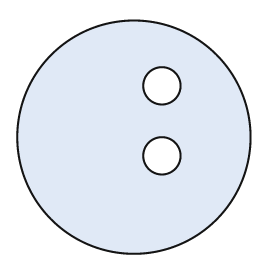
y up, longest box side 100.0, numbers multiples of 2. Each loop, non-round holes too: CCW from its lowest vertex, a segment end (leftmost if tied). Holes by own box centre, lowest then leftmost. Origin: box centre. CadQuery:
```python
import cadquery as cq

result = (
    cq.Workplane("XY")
    .moveTo(0.0, 0.0)
    .circle(50.0)
    .moveTo(12.0, -8.0)
    .circle(8.0)
    .moveTo(12.0, 22.0)
    .circle(8.0)
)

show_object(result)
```